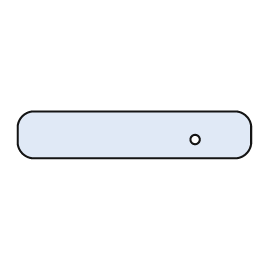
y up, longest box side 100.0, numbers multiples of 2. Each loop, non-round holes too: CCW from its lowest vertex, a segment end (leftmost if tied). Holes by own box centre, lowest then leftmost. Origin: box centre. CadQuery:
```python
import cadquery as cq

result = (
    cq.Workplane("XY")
    .moveTo(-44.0, -10.0)
    .lineTo(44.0, -10.0)
    .threePointArc((48.0, -8.0), (50.0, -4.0))
    .lineTo(50.0, 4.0)
    .threePointArc((48.0, 8.0), (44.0, 10.0))
    .lineTo(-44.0, 10.0)
    .threePointArc((-48.0, 8.0), (-50.0, 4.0))
    .lineTo(-50.0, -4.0)
    .threePointArc((-48.0, -8.0), (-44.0, -10.0))
    .close()
    .moveTo(26.0, -2.0)
    .circle(2.0)
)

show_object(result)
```